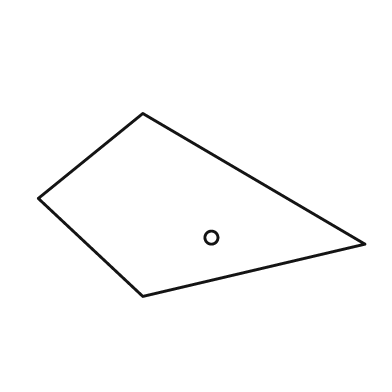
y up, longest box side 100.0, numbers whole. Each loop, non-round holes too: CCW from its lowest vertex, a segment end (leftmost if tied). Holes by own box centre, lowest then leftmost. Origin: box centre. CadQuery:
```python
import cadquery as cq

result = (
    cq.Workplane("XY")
    .moveTo(-18.0, -28.0)
    .lineTo(50.0, -12.0)
    .lineTo(-18.0, 28.0)
    .lineTo(-50.0, 2.0)
    .close()
    .moveTo(3.0, -10.0)
    .circle(2.0)
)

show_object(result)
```